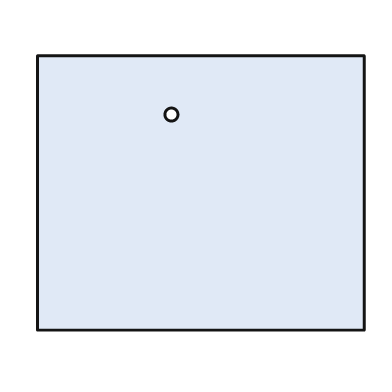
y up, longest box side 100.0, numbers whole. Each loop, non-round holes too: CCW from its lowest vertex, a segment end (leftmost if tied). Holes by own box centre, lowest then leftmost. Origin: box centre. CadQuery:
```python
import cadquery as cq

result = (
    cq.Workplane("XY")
    .moveTo(-50.0, -42.0)
    .lineTo(50.0, -42.0)
    .lineTo(50.0, 42.0)
    .lineTo(-50.0, 42.0)
    .close()
    .moveTo(-9.0, 24.0)
    .circle(2.0)
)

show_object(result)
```